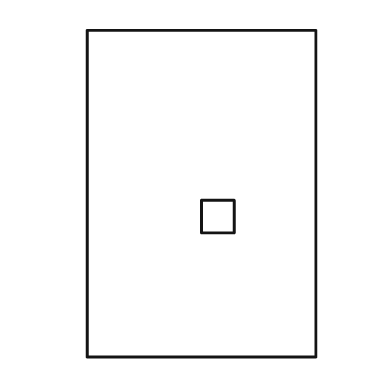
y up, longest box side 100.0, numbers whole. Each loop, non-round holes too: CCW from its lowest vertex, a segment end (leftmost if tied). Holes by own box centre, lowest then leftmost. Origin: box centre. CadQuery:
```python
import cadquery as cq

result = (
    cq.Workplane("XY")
    .moveTo(-35.0, -50.0)
    .lineTo(35.0, -50.0)
    .lineTo(35.0, 50.0)
    .lineTo(-35.0, 50.0)
    .close()
    .moveTo(0.0, -12.0)
    .lineTo(10.0, -12.0)
    .lineTo(10.0, -2.0)
    .lineTo(0.0, -2.0)
    .close()
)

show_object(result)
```